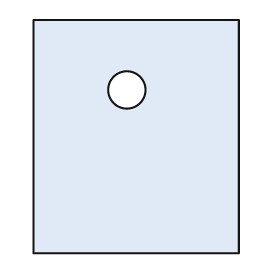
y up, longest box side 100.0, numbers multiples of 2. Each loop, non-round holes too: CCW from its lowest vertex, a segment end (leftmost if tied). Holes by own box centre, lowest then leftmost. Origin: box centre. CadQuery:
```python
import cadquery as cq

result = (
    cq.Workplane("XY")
    .moveTo(-44.0, -50.0)
    .lineTo(44.0, -50.0)
    .lineTo(44.0, 50.0)
    .lineTo(-44.0, 50.0)
    .close()
    .moveTo(-4.0, 20.0)
    .circle(8.0)
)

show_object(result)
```